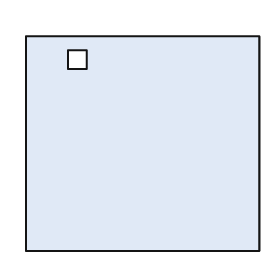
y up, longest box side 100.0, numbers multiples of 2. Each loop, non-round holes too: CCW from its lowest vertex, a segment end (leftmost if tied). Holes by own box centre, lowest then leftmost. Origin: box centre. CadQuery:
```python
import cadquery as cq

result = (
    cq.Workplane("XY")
    .moveTo(-50.0, -46.0)
    .lineTo(50.0, -46.0)
    .lineTo(50.0, 46.0)
    .lineTo(-50.0, 46.0)
    .close()
    .moveTo(-32.0, 32.0)
    .lineTo(-24.0, 32.0)
    .lineTo(-24.0, 40.0)
    .lineTo(-32.0, 40.0)
    .close()
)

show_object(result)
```